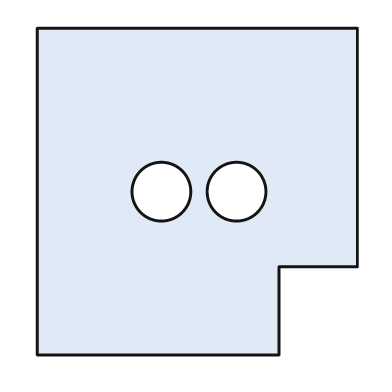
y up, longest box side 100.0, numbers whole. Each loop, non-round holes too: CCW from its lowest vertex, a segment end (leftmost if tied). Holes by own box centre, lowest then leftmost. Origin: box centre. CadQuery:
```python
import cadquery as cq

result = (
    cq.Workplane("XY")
    .moveTo(-49.0, -50.0)
    .lineTo(25.0, -50.0)
    .lineTo(25.0, -23.0)
    .lineTo(49.0, -23.0)
    .lineTo(49.0, 50.0)
    .lineTo(-49.0, 50.0)
    .close()
    .moveTo(-11.0, 0.0)
    .circle(9.0)
    .moveTo(12.0, 0.0)
    .circle(9.0)
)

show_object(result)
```